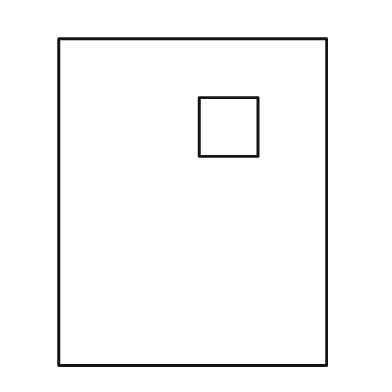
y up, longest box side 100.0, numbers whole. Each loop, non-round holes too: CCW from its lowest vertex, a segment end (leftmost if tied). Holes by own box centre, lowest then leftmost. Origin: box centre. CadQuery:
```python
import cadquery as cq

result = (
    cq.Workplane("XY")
    .moveTo(-41.0, -50.0)
    .lineTo(41.0, -50.0)
    .lineTo(41.0, 50.0)
    .lineTo(-41.0, 50.0)
    .close()
    .moveTo(2.0, 14.0)
    .lineTo(20.0, 14.0)
    .lineTo(20.0, 32.0)
    .lineTo(2.0, 32.0)
    .close()
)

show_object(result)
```